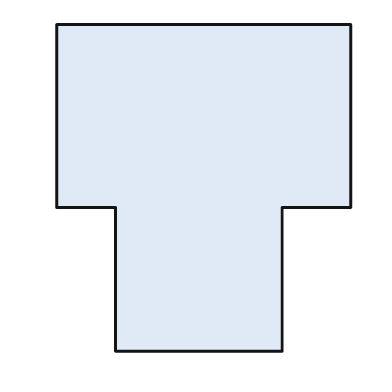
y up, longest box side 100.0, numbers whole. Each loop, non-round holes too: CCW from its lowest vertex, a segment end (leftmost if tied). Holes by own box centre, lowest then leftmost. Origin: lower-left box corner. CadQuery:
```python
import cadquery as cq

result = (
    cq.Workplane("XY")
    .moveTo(18.0, 0.0)
    .lineTo(69.0, 0.0)
    .lineTo(69.0, 44.0)
    .lineTo(90.0, 44.0)
    .lineTo(90.0, 100.0)
    .lineTo(0.0, 100.0)
    .lineTo(0.0, 44.0)
    .lineTo(18.0, 44.0)
    .close()
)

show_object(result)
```